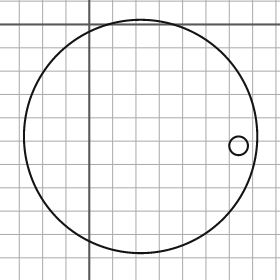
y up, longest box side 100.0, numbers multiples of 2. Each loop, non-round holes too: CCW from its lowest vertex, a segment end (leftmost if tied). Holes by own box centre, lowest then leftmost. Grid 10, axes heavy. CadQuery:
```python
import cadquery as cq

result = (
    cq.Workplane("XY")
    .moveTo(22.0, -48.0)
    .circle(50.0)
    .moveTo(64.0, -52.0)
    .circle(4.0)
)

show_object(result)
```